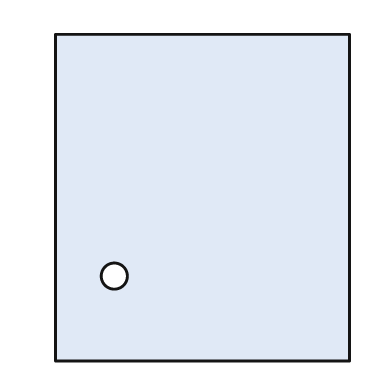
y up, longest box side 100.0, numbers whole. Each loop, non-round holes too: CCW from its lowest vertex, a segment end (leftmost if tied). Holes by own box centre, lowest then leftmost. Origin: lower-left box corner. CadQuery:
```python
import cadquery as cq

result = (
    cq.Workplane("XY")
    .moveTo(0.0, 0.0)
    .lineTo(90.0, 0.0)
    .lineTo(90.0, 100.0)
    .lineTo(0.0, 100.0)
    .close()
    .moveTo(18.0, 26.0)
    .circle(4.0)
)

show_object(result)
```